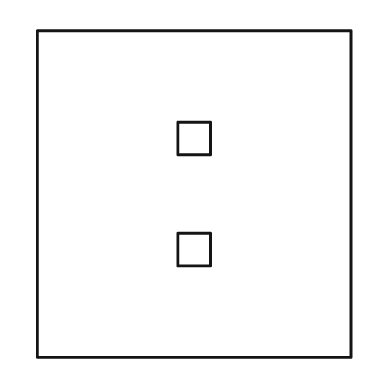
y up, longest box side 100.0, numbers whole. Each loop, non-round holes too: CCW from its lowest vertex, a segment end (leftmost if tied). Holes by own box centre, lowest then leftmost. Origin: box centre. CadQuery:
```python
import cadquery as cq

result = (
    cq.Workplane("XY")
    .moveTo(-48.0, -50.0)
    .lineTo(48.0, -50.0)
    .lineTo(48.0, 50.0)
    .lineTo(-48.0, 50.0)
    .close()
    .moveTo(-5.0, -22.0)
    .lineTo(5.0, -22.0)
    .lineTo(5.0, -12.0)
    .lineTo(-5.0, -12.0)
    .close()
    .moveTo(-5.0, 12.0)
    .lineTo(5.0, 12.0)
    .lineTo(5.0, 22.0)
    .lineTo(-5.0, 22.0)
    .close()
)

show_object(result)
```